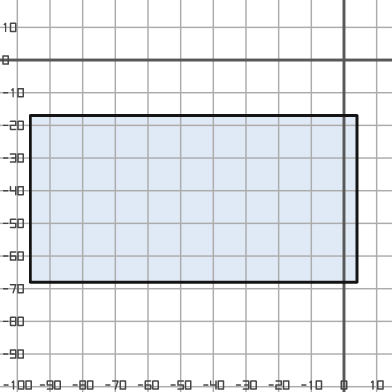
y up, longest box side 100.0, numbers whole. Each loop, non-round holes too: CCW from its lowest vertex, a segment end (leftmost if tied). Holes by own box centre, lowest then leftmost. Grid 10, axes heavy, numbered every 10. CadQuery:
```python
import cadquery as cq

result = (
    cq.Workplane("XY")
    .moveTo(-96.0, -68.0)
    .lineTo(4.0, -68.0)
    .lineTo(4.0, -17.0)
    .lineTo(-96.0, -17.0)
    .close()
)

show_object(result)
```